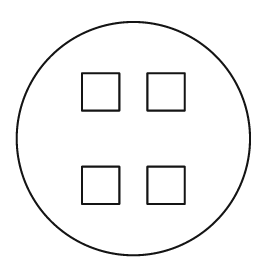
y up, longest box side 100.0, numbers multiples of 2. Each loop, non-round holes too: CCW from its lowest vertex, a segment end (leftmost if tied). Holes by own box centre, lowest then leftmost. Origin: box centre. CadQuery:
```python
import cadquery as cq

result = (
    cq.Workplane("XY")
    .moveTo(0.0, 0.0)
    .circle(50.0)
    .moveTo(-22.0, -28.0)
    .lineTo(-6.0, -28.0)
    .lineTo(-6.0, -12.0)
    .lineTo(-22.0, -12.0)
    .close()
    .moveTo(6.0, -28.0)
    .lineTo(22.0, -28.0)
    .lineTo(22.0, -12.0)
    .lineTo(6.0, -12.0)
    .close()
    .moveTo(-22.0, 12.0)
    .lineTo(-6.0, 12.0)
    .lineTo(-6.0, 28.0)
    .lineTo(-22.0, 28.0)
    .close()
    .moveTo(6.0, 12.0)
    .lineTo(22.0, 12.0)
    .lineTo(22.0, 28.0)
    .lineTo(6.0, 28.0)
    .close()
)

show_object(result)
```